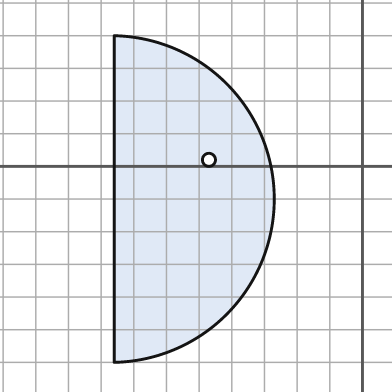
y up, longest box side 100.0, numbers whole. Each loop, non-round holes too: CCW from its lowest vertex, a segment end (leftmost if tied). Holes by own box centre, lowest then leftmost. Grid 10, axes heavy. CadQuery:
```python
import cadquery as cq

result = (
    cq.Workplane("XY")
    .moveTo(-76.0, -60.0)
    .threePointArc((-27.0, -10.0), (-76.0, 40.0))
    .close()
    .moveTo(-47.0, 2.0)
    .circle(2.0)
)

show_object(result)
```